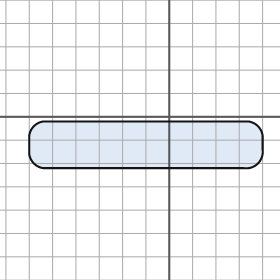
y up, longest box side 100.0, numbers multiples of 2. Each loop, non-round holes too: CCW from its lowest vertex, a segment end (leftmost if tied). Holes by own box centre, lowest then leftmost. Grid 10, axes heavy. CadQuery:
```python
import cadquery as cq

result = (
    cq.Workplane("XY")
    .moveTo(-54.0, -22.0)
    .lineTo(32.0, -22.0)
    .threePointArc((38.0, -20.0), (40.0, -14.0))
    .lineTo(40.0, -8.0)
    .threePointArc((38.0, -4.0), (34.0, -2.0))
    .lineTo(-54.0, -2.0)
    .threePointArc((-58.0, -4.0), (-60.0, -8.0))
    .lineTo(-60.0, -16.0)
    .threePointArc((-58.0, -20.0), (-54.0, -22.0))
    .close()
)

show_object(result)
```